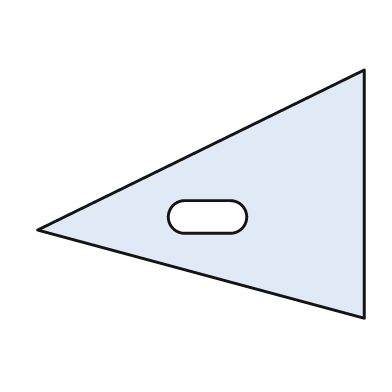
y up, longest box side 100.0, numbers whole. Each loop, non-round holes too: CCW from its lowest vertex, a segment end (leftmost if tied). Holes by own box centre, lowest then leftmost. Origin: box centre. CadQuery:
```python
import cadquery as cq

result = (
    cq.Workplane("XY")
    .moveTo(50.0, -38.0)
    .lineTo(50.0, 38.0)
    .lineTo(-50.0, -11.0)
    .close()
    .moveTo(-5.0, -12.0)
    .lineTo(9.0, -12.0)
    .threePointArc((14.0, -7.0), (9.0, -2.0))
    .lineTo(-5.0, -2.0)
    .threePointArc((-10.0, -7.0), (-5.0, -12.0))
    .close()
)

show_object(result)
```